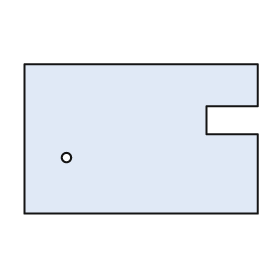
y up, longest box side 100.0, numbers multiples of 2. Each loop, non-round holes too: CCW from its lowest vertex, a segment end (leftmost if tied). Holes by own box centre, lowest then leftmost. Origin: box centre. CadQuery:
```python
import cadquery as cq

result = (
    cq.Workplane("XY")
    .moveTo(-50.0, -32.0)
    .lineTo(50.0, -32.0)
    .lineTo(50.0, 2.0)
    .lineTo(28.0, 2.0)
    .lineTo(28.0, 14.0)
    .lineTo(50.0, 14.0)
    .lineTo(50.0, 32.0)
    .lineTo(-50.0, 32.0)
    .close()
    .moveTo(-32.0, -8.0)
    .circle(2.0)
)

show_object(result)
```